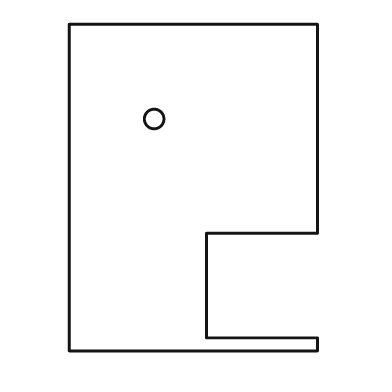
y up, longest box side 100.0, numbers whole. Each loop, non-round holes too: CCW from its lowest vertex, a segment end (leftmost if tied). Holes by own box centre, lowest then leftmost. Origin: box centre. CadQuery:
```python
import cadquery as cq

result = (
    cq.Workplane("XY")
    .moveTo(-38.0, -50.0)
    .lineTo(38.0, -50.0)
    .lineTo(38.0, -46.0)
    .lineTo(4.0, -46.0)
    .lineTo(4.0, -14.0)
    .lineTo(38.0, -14.0)
    .lineTo(38.0, 50.0)
    .lineTo(-38.0, 50.0)
    .close()
    .moveTo(-12.0, 21.0)
    .circle(3.0)
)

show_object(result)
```